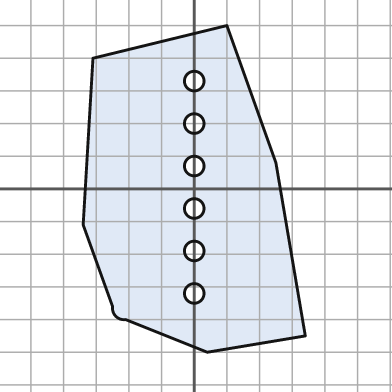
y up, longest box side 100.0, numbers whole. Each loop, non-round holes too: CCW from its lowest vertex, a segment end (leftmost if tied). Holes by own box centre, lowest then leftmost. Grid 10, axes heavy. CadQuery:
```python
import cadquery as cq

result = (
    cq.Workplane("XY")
    .moveTo(4.0, -50.0)
    .lineTo(34.0, -45.0)
    .lineTo(25.0, 8.0)
    .lineTo(10.0, 50.0)
    .lineTo(-31.0, 40.0)
    .lineTo(-34.0, -11.0)
    .lineTo(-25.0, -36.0)
    .threePointArc((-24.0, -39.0), (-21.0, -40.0))
    .close()
    .moveTo(0.0, -32.0)
    .circle(3.0)
    .moveTo(0.0, -19.0)
    .circle(3.0)
    .moveTo(0.0, -6.0)
    .circle(3.0)
    .moveTo(0.0, 7.0)
    .circle(3.0)
    .moveTo(0.0, 20.0)
    .circle(3.0)
    .moveTo(0.0, 33.0)
    .circle(3.0)
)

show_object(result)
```